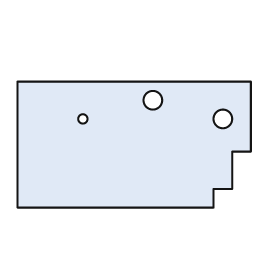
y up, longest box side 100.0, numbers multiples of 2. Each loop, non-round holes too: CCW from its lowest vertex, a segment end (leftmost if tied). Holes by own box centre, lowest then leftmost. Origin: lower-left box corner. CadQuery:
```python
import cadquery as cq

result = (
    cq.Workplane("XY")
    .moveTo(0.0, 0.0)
    .lineTo(84.0, 0.0)
    .lineTo(84.0, 8.0)
    .lineTo(92.0, 8.0)
    .lineTo(92.0, 24.0)
    .lineTo(100.0, 24.0)
    .lineTo(100.0, 54.0)
    .lineTo(0.0, 54.0)
    .close()
    .moveTo(28.0, 38.0)
    .circle(2.0)
    .moveTo(88.0, 38.0)
    .circle(4.0)
    .moveTo(58.0, 46.0)
    .circle(4.0)
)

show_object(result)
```